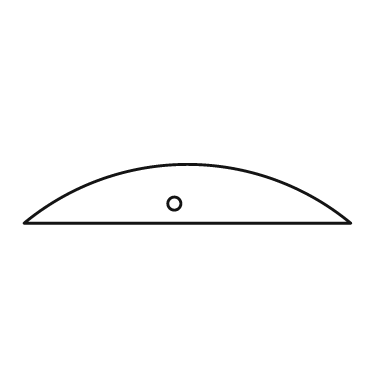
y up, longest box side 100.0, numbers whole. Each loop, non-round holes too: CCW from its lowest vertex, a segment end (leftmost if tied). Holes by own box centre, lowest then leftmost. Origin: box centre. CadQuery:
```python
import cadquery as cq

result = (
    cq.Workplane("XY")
    .moveTo(-50.0, -9.0)
    .lineTo(50.0, -9.0)
    .threePointArc((0.0, 9.0), (-50.0, -9.0))
    .close()
    .moveTo(-4.0, -3.0)
    .circle(2.0)
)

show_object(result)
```